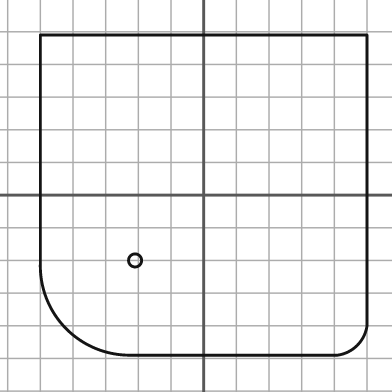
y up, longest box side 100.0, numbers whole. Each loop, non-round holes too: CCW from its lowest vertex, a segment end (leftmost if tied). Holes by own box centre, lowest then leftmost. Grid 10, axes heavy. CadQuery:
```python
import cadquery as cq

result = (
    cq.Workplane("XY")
    .moveTo(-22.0, -49.0)
    .lineTo(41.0, -49.0)
    .threePointArc((47.0, -46.0), (50.0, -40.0))
    .lineTo(50.0, 49.0)
    .lineTo(-50.0, 49.0)
    .lineTo(-50.0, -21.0)
    .threePointArc((-42.0, -41.0), (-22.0, -49.0))
    .close()
    .moveTo(-21.0, -20.0)
    .circle(2.0)
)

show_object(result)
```